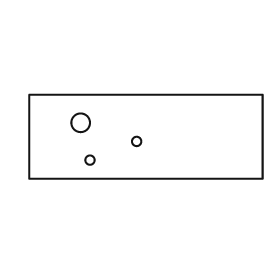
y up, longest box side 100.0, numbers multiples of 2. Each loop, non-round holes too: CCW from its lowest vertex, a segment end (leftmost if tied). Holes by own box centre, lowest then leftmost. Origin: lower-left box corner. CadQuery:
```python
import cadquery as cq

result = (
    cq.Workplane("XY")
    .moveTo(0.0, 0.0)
    .lineTo(100.0, 0.0)
    .lineTo(100.0, 36.0)
    .lineTo(0.0, 36.0)
    .close()
    .moveTo(26.0, 8.0)
    .circle(2.0)
    .moveTo(46.0, 16.0)
    .circle(2.0)
    .moveTo(22.0, 24.0)
    .circle(4.0)
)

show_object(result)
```